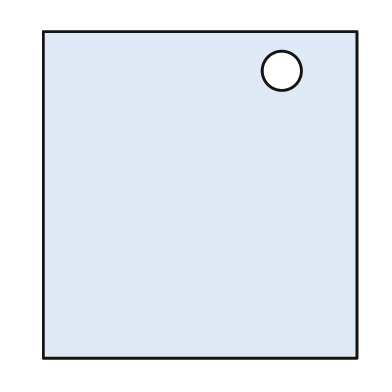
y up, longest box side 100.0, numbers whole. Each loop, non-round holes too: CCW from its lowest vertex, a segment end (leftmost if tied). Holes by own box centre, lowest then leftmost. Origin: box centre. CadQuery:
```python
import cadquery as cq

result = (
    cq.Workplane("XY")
    .moveTo(-48.0, -50.0)
    .lineTo(48.0, -50.0)
    .lineTo(48.0, 50.0)
    .lineTo(-48.0, 50.0)
    .close()
    .moveTo(25.0, 38.0)
    .circle(6.0)
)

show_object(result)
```